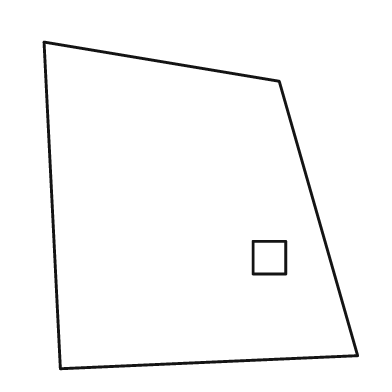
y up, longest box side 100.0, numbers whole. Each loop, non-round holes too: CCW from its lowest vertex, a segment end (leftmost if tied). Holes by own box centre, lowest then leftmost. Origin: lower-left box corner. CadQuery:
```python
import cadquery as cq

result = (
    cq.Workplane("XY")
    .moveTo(5.0, 0.0)
    .lineTo(96.0, 4.0)
    .lineTo(72.0, 88.0)
    .lineTo(0.0, 100.0)
    .close()
    .moveTo(64.0, 29.0)
    .lineTo(74.0, 29.0)
    .lineTo(74.0, 39.0)
    .lineTo(64.0, 39.0)
    .close()
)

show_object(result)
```